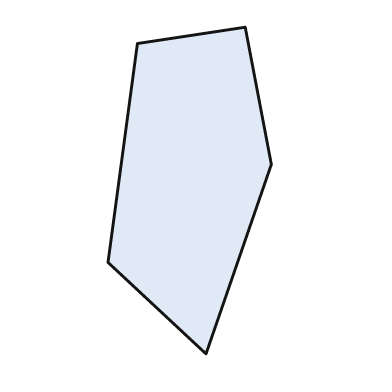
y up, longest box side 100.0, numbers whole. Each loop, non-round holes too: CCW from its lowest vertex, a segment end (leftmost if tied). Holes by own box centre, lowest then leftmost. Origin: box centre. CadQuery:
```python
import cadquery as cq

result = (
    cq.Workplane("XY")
    .moveTo(5.0, -50.0)
    .lineTo(25.0, 8.0)
    .lineTo(17.0, 50.0)
    .lineTo(-16.0, 45.0)
    .lineTo(-25.0, -22.0)
    .close()
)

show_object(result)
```